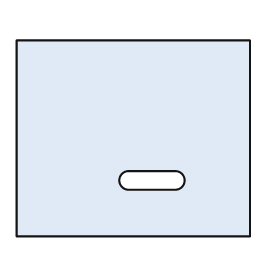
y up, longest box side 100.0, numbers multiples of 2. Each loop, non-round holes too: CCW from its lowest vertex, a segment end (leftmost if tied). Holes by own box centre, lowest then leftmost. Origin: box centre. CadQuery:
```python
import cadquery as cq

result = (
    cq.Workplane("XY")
    .moveTo(-50.0, -42.0)
    .lineTo(50.0, -42.0)
    .lineTo(50.0, 42.0)
    .lineTo(-50.0, 42.0)
    .close()
    .moveTo(-2.0, -22.0)
    .lineTo(18.0, -22.0)
    .threePointArc((22.0, -18.0), (18.0, -14.0))
    .lineTo(-2.0, -14.0)
    .threePointArc((-6.0, -18.0), (-2.0, -22.0))
    .close()
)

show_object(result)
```